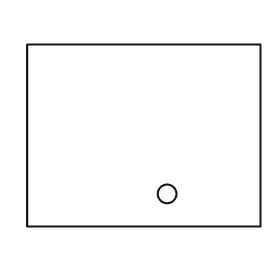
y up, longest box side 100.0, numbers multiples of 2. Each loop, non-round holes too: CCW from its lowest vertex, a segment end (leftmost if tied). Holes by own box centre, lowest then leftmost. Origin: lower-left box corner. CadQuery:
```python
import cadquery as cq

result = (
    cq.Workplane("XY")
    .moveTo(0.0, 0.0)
    .lineTo(100.0, 0.0)
    .lineTo(100.0, 78.0)
    .lineTo(0.0, 78.0)
    .close()
    .moveTo(60.0, 14.0)
    .circle(4.0)
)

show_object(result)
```